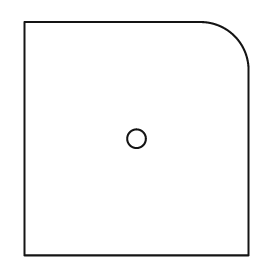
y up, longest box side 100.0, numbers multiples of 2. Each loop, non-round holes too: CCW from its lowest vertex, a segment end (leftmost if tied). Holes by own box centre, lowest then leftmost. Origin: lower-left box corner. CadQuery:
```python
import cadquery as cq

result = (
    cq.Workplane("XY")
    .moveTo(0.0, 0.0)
    .lineTo(96.0, 0.0)
    .lineTo(96.0, 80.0)
    .threePointArc((90.0, 94.0), (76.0, 100.0))
    .lineTo(0.0, 100.0)
    .close()
    .moveTo(48.0, 50.0)
    .circle(4.0)
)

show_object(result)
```